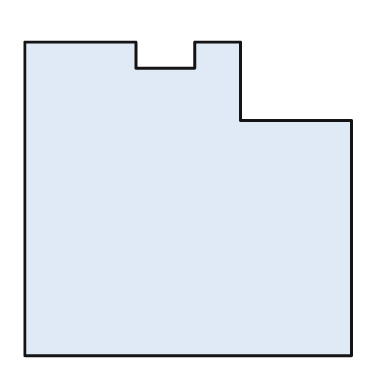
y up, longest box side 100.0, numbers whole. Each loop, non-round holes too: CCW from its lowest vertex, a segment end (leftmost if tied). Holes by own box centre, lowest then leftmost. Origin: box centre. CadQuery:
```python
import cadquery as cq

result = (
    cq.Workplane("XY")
    .moveTo(-50.0, -48.0)
    .lineTo(50.0, -48.0)
    .lineTo(50.0, 24.0)
    .lineTo(16.0, 24.0)
    .lineTo(16.0, 48.0)
    .lineTo(2.0, 48.0)
    .lineTo(2.0, 40.0)
    .lineTo(-16.0, 40.0)
    .lineTo(-16.0, 48.0)
    .lineTo(-50.0, 48.0)
    .close()
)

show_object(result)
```